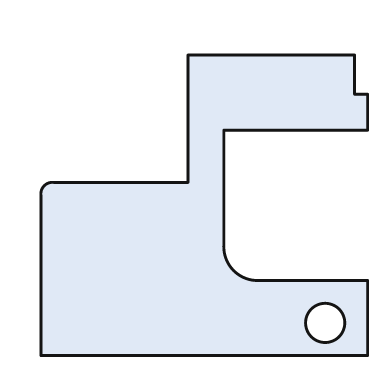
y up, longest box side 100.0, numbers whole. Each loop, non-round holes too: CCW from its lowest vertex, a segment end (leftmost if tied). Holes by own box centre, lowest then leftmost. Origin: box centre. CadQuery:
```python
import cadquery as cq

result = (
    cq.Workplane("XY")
    .moveTo(-50.0, -46.0)
    .lineTo(50.0, -46.0)
    .lineTo(50.0, -23.0)
    .lineTo(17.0, -23.0)
    .threePointArc((9.0, -20.0), (6.0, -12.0))
    .lineTo(6.0, 23.0)
    .lineTo(50.0, 23.0)
    .lineTo(50.0, 34.0)
    .lineTo(46.0, 34.0)
    .lineTo(46.0, 46.0)
    .lineTo(-5.0, 46.0)
    .lineTo(-5.0, 7.0)
    .lineTo(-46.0, 7.0)
    .threePointArc((-49.0, 6.0), (-50.0, 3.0))
    .close()
    .moveTo(37.0, -36.0)
    .circle(6.0)
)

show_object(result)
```